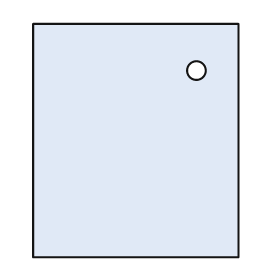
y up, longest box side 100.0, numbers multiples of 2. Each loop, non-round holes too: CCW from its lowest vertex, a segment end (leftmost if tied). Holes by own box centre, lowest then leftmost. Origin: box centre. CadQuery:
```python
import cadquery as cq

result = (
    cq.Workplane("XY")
    .moveTo(-44.0, -50.0)
    .lineTo(44.0, -50.0)
    .lineTo(44.0, 50.0)
    .lineTo(-44.0, 50.0)
    .close()
    .moveTo(26.0, 30.0)
    .circle(4.0)
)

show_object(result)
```